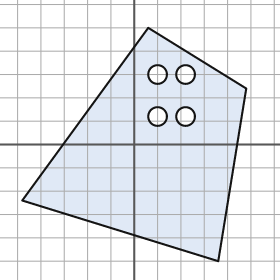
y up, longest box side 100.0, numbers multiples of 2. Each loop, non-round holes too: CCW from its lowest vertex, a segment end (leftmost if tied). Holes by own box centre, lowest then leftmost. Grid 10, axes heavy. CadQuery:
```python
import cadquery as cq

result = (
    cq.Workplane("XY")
    .moveTo(36.0, -50.0)
    .lineTo(48.0, 24.0)
    .lineTo(6.0, 50.0)
    .lineTo(-48.0, -24.0)
    .close()
    .moveTo(10.0, 12.0)
    .circle(4.0)
    .moveTo(22.0, 12.0)
    .circle(4.0)
    .moveTo(10.0, 30.0)
    .circle(4.0)
    .moveTo(22.0, 30.0)
    .circle(4.0)
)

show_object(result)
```